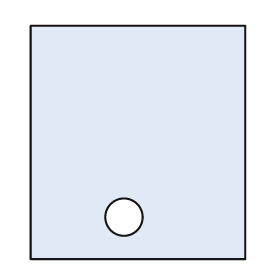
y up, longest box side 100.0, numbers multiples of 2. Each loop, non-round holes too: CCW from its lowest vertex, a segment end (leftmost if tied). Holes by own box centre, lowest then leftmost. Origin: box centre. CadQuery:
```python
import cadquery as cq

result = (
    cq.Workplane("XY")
    .moveTo(-46.0, -50.0)
    .lineTo(46.0, -50.0)
    .lineTo(46.0, 50.0)
    .lineTo(-46.0, 50.0)
    .close()
    .moveTo(-6.0, -32.0)
    .circle(8.0)
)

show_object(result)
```